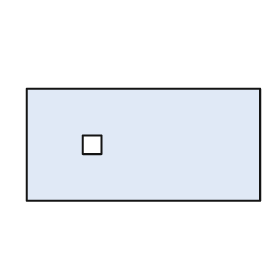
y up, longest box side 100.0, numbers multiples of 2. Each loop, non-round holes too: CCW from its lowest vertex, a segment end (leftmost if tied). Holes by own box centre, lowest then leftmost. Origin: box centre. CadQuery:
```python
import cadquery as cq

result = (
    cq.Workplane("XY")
    .moveTo(-50.0, -24.0)
    .lineTo(50.0, -24.0)
    .lineTo(50.0, 24.0)
    .lineTo(-50.0, 24.0)
    .close()
    .moveTo(-26.0, -4.0)
    .lineTo(-18.0, -4.0)
    .lineTo(-18.0, 4.0)
    .lineTo(-26.0, 4.0)
    .close()
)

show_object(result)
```